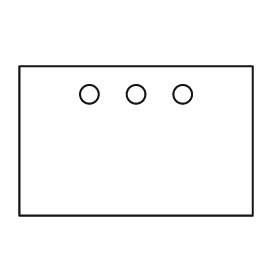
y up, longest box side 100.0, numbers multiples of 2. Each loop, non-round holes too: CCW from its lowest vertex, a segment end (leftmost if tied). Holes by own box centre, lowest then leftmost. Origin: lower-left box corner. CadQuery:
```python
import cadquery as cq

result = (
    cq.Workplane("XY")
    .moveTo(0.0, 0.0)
    .lineTo(100.0, 0.0)
    .lineTo(100.0, 64.0)
    .lineTo(0.0, 64.0)
    .close()
    .moveTo(30.0, 52.0)
    .circle(4.0)
    .moveTo(50.0, 52.0)
    .circle(4.0)
    .moveTo(70.0, 52.0)
    .circle(4.0)
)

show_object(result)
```